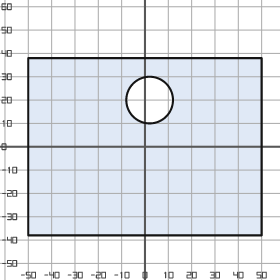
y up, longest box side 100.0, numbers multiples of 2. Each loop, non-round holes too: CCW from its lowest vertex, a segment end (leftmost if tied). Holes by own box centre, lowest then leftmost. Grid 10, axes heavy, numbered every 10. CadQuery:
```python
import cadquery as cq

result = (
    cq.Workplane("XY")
    .moveTo(-50.0, -38.0)
    .lineTo(50.0, -38.0)
    .lineTo(50.0, 38.0)
    .lineTo(-50.0, 38.0)
    .close()
    .moveTo(2.0, 20.0)
    .circle(10.0)
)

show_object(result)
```